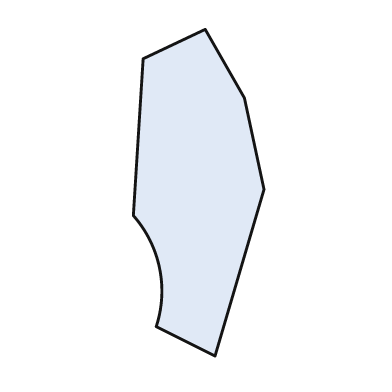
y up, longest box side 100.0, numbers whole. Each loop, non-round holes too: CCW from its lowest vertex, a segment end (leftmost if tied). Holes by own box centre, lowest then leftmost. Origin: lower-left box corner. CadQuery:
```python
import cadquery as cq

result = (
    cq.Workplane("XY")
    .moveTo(25.0, 0.0)
    .lineTo(40.0, 51.0)
    .lineTo(34.0, 79.0)
    .lineTo(22.0, 100.0)
    .lineTo(3.0, 91.0)
    .lineTo(0.0, 43.0)
    .threePointArc((8.0, 27.0), (7.0, 9.0))
    .close()
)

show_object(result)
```